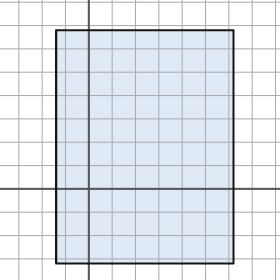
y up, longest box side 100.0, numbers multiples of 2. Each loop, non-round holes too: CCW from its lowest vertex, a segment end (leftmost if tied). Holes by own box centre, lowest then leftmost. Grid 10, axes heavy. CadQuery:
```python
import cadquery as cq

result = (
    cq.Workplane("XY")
    .moveTo(-14.0, -32.0)
    .lineTo(62.0, -32.0)
    .lineTo(62.0, 68.0)
    .lineTo(-14.0, 68.0)
    .close()
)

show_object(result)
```